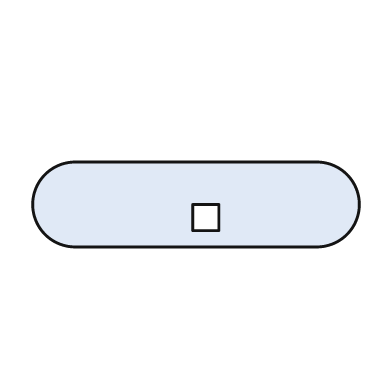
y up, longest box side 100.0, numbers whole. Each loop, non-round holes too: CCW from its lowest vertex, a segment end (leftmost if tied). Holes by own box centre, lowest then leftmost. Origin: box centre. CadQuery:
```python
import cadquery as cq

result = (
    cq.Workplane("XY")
    .moveTo(-37.0, -13.0)
    .lineTo(37.0, -13.0)
    .threePointArc((50.0, 0.0), (37.0, 13.0))
    .lineTo(-37.0, 13.0)
    .threePointArc((-50.0, 0.0), (-37.0, -13.0))
    .close()
    .moveTo(-1.0, -8.0)
    .lineTo(7.0, -8.0)
    .lineTo(7.0, 0.0)
    .lineTo(-1.0, 0.0)
    .close()
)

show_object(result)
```